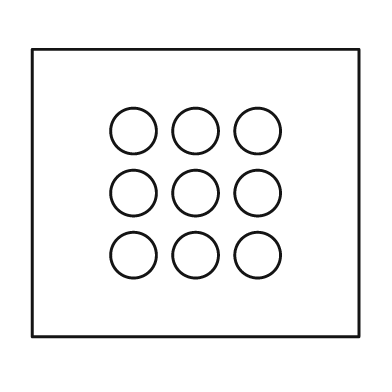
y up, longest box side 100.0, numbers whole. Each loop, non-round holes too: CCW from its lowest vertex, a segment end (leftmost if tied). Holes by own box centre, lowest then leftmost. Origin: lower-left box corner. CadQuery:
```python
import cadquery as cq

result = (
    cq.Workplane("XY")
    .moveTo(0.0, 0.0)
    .lineTo(100.0, 0.0)
    .lineTo(100.0, 88.0)
    .lineTo(0.0, 88.0)
    .close()
    .moveTo(31.0, 25.0)
    .circle(7.0)
    .moveTo(50.0, 25.0)
    .circle(7.0)
    .moveTo(69.0, 25.0)
    .circle(7.0)
    .moveTo(31.0, 44.0)
    .circle(7.0)
    .moveTo(50.0, 44.0)
    .circle(7.0)
    .moveTo(69.0, 44.0)
    .circle(7.0)
    .moveTo(31.0, 63.0)
    .circle(7.0)
    .moveTo(50.0, 63.0)
    .circle(7.0)
    .moveTo(69.0, 63.0)
    .circle(7.0)
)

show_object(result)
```